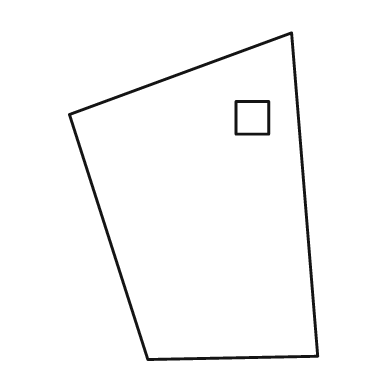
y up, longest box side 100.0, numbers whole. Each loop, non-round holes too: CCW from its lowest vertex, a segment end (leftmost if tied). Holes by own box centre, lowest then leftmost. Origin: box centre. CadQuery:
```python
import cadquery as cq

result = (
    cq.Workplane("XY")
    .moveTo(-14.0, -50.0)
    .lineTo(38.0, -49.0)
    .lineTo(30.0, 50.0)
    .lineTo(-38.0, 25.0)
    .close()
    .moveTo(13.0, 19.0)
    .lineTo(23.0, 19.0)
    .lineTo(23.0, 29.0)
    .lineTo(13.0, 29.0)
    .close()
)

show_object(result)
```